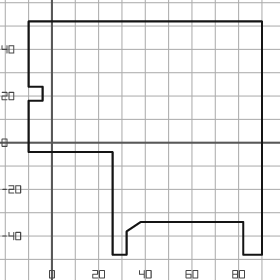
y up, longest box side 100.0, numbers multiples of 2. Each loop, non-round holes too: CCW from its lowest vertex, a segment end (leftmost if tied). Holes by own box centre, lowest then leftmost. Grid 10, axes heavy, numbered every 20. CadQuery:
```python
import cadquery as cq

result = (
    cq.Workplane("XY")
    .moveTo(26.0, -48.0)
    .lineTo(32.0, -48.0)
    .lineTo(32.0, -38.0)
    .lineTo(38.0, -34.0)
    .lineTo(82.0, -34.0)
    .lineTo(82.0, -48.0)
    .lineTo(90.0, -48.0)
    .lineTo(90.0, 52.0)
    .lineTo(-10.0, 52.0)
    .lineTo(-10.0, 24.0)
    .lineTo(-4.0, 24.0)
    .lineTo(-4.0, 18.0)
    .lineTo(-10.0, 18.0)
    .lineTo(-10.0, -4.0)
    .lineTo(26.0, -4.0)
    .close()
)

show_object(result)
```